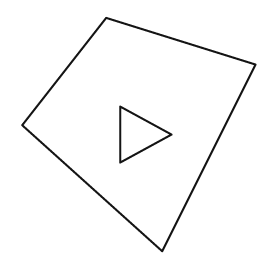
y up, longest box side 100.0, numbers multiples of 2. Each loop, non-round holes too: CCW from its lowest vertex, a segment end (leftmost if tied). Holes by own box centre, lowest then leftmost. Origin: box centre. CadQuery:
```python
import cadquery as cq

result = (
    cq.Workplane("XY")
    .moveTo(10.0, -50.0)
    .lineTo(50.0, 30.0)
    .lineTo(-14.0, 50.0)
    .lineTo(-50.0, 4.0)
    .close()
    .moveTo(-8.0, -12.0)
    .lineTo(14.0, 0.0)
    .lineTo(-8.0, 12.0)
    .close()
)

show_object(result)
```